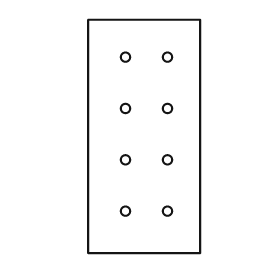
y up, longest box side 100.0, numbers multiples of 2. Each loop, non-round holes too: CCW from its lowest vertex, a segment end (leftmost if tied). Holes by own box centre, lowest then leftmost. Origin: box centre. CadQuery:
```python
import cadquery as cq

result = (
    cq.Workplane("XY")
    .moveTo(-24.0, -50.0)
    .lineTo(24.0, -50.0)
    .lineTo(24.0, 50.0)
    .lineTo(-24.0, 50.0)
    .close()
    .moveTo(-8.0, -32.0)
    .circle(2.0)
    .moveTo(10.0, -32.0)
    .circle(2.0)
    .moveTo(-8.0, -10.0)
    .circle(2.0)
    .moveTo(10.0, -10.0)
    .circle(2.0)
    .moveTo(-8.0, 12.0)
    .circle(2.0)
    .moveTo(10.0, 12.0)
    .circle(2.0)
    .moveTo(-8.0, 34.0)
    .circle(2.0)
    .moveTo(10.0, 34.0)
    .circle(2.0)
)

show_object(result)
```